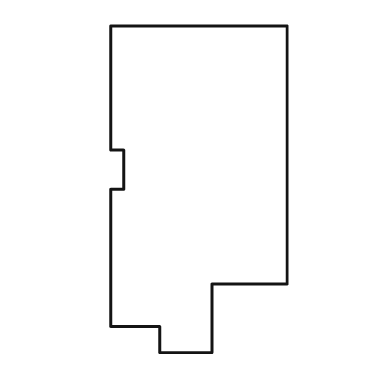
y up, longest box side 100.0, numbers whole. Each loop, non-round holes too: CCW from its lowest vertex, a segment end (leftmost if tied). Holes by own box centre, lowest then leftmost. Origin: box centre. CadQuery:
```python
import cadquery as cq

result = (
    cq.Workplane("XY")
    .moveTo(-12.0, -50.0)
    .lineTo(4.0, -50.0)
    .lineTo(4.0, -29.0)
    .lineTo(27.0, -29.0)
    .lineTo(27.0, 50.0)
    .lineTo(-27.0, 50.0)
    .lineTo(-27.0, 12.0)
    .lineTo(-23.0, 12.0)
    .lineTo(-23.0, 0.0)
    .lineTo(-27.0, 0.0)
    .lineTo(-27.0, -42.0)
    .lineTo(-12.0, -42.0)
    .close()
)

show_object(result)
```